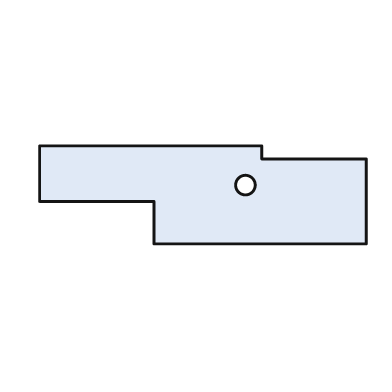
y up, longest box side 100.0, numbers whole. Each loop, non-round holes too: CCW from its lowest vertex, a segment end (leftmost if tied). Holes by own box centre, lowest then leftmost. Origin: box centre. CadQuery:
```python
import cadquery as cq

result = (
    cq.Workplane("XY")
    .moveTo(-15.0, -15.0)
    .lineTo(50.0, -15.0)
    .lineTo(50.0, 11.0)
    .lineTo(18.0, 11.0)
    .lineTo(18.0, 15.0)
    .lineTo(-50.0, 15.0)
    .lineTo(-50.0, -2.0)
    .lineTo(-15.0, -2.0)
    .close()
    .moveTo(13.0, 3.0)
    .circle(3.0)
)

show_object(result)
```